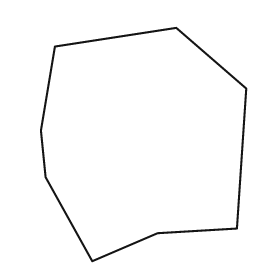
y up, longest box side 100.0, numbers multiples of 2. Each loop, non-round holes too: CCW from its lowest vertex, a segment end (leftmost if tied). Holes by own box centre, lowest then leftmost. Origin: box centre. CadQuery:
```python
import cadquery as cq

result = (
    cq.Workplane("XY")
    .moveTo(-22.0, -50.0)
    .lineTo(6.0, -38.0)
    .lineTo(40.0, -36.0)
    .lineTo(44.0, 24.0)
    .lineTo(14.0, 50.0)
    .lineTo(-38.0, 42.0)
    .lineTo(-44.0, 6.0)
    .lineTo(-42.0, -14.0)
    .close()
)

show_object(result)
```